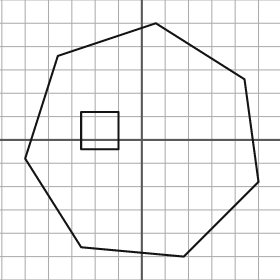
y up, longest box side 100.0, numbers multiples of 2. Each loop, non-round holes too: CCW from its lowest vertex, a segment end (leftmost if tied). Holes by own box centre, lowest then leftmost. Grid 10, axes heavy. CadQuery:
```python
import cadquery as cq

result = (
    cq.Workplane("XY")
    .moveTo(18.0, -50.0)
    .lineTo(50.0, -18.0)
    .lineTo(44.0, 26.0)
    .lineTo(6.0, 50.0)
    .lineTo(-36.0, 36.0)
    .lineTo(-50.0, -8.0)
    .lineTo(-26.0, -46.0)
    .close()
    .moveTo(-26.0, -4.0)
    .lineTo(-10.0, -4.0)
    .lineTo(-10.0, 12.0)
    .lineTo(-26.0, 12.0)
    .close()
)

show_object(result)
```